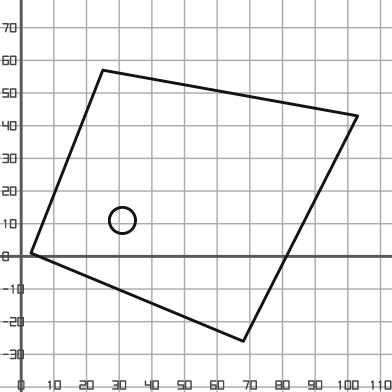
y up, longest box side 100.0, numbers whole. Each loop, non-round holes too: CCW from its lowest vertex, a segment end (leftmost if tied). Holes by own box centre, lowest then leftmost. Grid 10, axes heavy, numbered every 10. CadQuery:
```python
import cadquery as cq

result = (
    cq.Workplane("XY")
    .moveTo(68.0, -26.0)
    .lineTo(103.0, 43.0)
    .lineTo(25.0, 57.0)
    .lineTo(3.0, 1.0)
    .close()
    .moveTo(31.0, 11.0)
    .circle(4.0)
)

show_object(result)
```